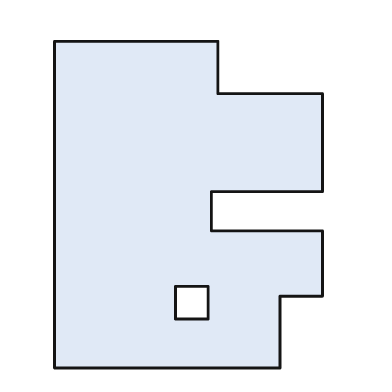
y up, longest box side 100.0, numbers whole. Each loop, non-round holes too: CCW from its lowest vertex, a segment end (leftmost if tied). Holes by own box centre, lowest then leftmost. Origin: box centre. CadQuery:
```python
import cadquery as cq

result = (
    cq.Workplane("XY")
    .moveTo(-41.0, -50.0)
    .lineTo(28.0, -50.0)
    .lineTo(28.0, -28.0)
    .lineTo(41.0, -28.0)
    .lineTo(41.0, -8.0)
    .lineTo(7.0, -8.0)
    .lineTo(7.0, 4.0)
    .lineTo(41.0, 4.0)
    .lineTo(41.0, 34.0)
    .lineTo(9.0, 34.0)
    .lineTo(9.0, 50.0)
    .lineTo(-41.0, 50.0)
    .close()
    .moveTo(-4.0, -35.0)
    .lineTo(6.0, -35.0)
    .lineTo(6.0, -25.0)
    .lineTo(-4.0, -25.0)
    .close()
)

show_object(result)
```